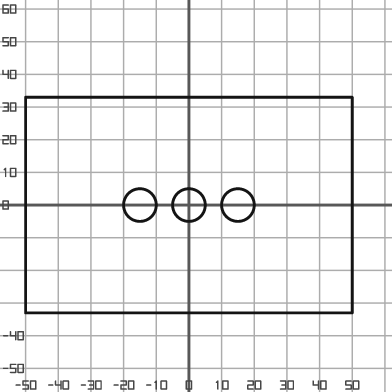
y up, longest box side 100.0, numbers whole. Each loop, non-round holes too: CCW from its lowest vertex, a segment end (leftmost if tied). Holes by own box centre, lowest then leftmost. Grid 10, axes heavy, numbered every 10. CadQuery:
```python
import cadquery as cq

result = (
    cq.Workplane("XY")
    .moveTo(-50.0, -33.0)
    .lineTo(50.0, -33.0)
    .lineTo(50.0, 33.0)
    .lineTo(-50.0, 33.0)
    .close()
    .moveTo(-15.0, 0.0)
    .circle(5.0)
    .moveTo(0.0, 0.0)
    .circle(5.0)
    .moveTo(15.0, 0.0)
    .circle(5.0)
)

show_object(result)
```